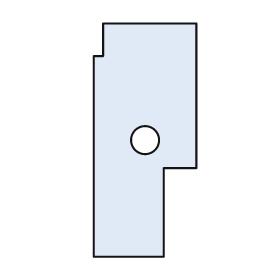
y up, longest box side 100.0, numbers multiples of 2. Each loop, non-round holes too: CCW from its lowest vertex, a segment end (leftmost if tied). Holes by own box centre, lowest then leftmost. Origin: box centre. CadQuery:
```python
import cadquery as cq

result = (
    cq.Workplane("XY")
    .moveTo(-22.0, -50.0)
    .lineTo(8.0, -50.0)
    .lineTo(8.0, -12.0)
    .lineTo(22.0, -12.0)
    .lineTo(22.0, 50.0)
    .lineTo(-18.0, 50.0)
    .lineTo(-18.0, 36.0)
    .lineTo(-22.0, 36.0)
    .close()
    .moveTo(0.0, 0.0)
    .circle(6.0)
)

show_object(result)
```